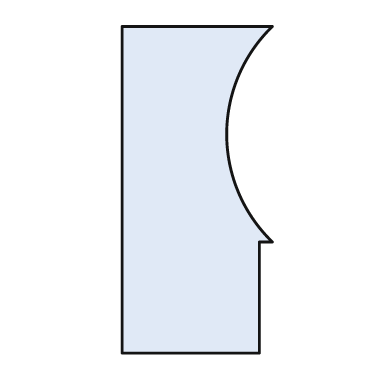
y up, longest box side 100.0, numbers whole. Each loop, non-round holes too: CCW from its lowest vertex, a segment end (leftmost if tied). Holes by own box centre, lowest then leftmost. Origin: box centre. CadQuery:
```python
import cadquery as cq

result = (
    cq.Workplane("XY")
    .moveTo(-23.0, -50.0)
    .lineTo(19.0, -50.0)
    .lineTo(19.0, -16.0)
    .lineTo(23.0, -16.0)
    .threePointArc((9.0, 17.0), (23.0, 50.0))
    .lineTo(-23.0, 50.0)
    .close()
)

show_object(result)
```